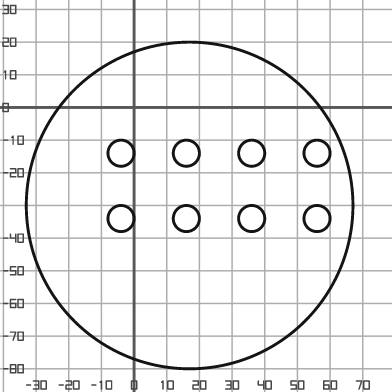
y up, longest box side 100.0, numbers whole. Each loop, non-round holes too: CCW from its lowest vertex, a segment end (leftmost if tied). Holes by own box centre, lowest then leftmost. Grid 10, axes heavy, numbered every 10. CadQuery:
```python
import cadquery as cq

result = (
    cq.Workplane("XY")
    .moveTo(17.0, -30.0)
    .circle(50.0)
    .moveTo(-4.0, -34.0)
    .circle(4.0)
    .moveTo(16.0, -34.0)
    .circle(4.0)
    .moveTo(36.0, -34.0)
    .circle(4.0)
    .moveTo(56.0, -34.0)
    .circle(4.0)
    .moveTo(-4.0, -14.0)
    .circle(4.0)
    .moveTo(16.0, -14.0)
    .circle(4.0)
    .moveTo(36.0, -14.0)
    .circle(4.0)
    .moveTo(56.0, -14.0)
    .circle(4.0)
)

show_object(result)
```